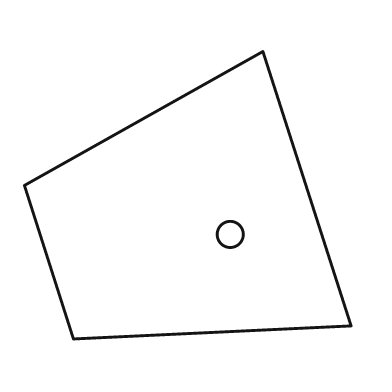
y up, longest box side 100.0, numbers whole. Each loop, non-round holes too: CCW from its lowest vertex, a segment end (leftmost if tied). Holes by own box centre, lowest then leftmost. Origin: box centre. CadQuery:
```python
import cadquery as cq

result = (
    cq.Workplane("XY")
    .moveTo(-35.0, -44.0)
    .lineTo(50.0, -40.0)
    .lineTo(23.0, 44.0)
    .lineTo(-50.0, 3.0)
    .close()
    .moveTo(13.0, -12.0)
    .circle(4.0)
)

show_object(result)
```